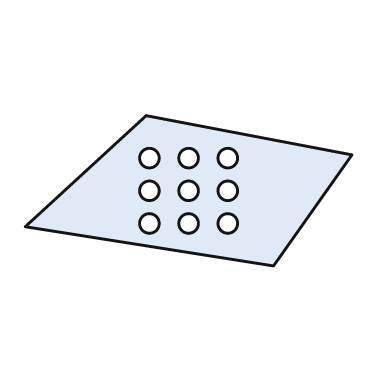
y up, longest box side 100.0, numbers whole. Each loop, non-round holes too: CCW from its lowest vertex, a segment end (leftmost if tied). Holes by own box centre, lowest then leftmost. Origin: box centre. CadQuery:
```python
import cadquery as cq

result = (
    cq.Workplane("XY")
    .moveTo(26.0, -23.0)
    .lineTo(50.0, 11.0)
    .lineTo(-13.0, 23.0)
    .lineTo(-50.0, -11.0)
    .close()
    .moveTo(-12.0, -10.0)
    .circle(3.0)
    .moveTo(0.0, -10.0)
    .circle(3.0)
    .moveTo(12.0, -10.0)
    .circle(3.0)
    .moveTo(-12.0, 0.0)
    .circle(3.0)
    .moveTo(0.0, 0.0)
    .circle(3.0)
    .moveTo(12.0, 0.0)
    .circle(3.0)
    .moveTo(-12.0, 10.0)
    .circle(3.0)
    .moveTo(0.0, 10.0)
    .circle(3.0)
    .moveTo(12.0, 10.0)
    .circle(3.0)
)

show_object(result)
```